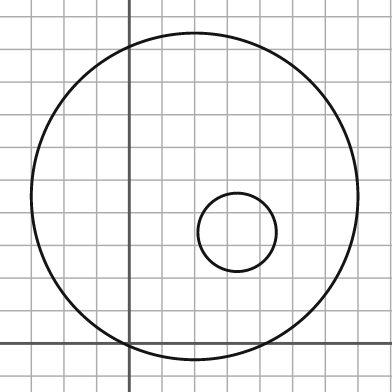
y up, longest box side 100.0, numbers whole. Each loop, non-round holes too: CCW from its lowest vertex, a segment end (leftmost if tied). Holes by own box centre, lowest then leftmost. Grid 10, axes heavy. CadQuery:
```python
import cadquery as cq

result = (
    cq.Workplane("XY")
    .moveTo(20.0, 45.0)
    .circle(50.0)
    .moveTo(33.0, 34.0)
    .circle(12.0)
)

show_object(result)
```